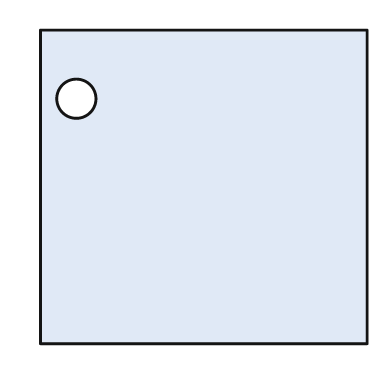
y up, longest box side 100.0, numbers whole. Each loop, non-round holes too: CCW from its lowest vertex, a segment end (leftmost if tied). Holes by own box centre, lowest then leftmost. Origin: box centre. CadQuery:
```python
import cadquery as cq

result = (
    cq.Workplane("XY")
    .moveTo(-50.0, -48.0)
    .lineTo(50.0, -48.0)
    .lineTo(50.0, 48.0)
    .lineTo(-50.0, 48.0)
    .close()
    .moveTo(-39.0, 27.0)
    .circle(6.0)
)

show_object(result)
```